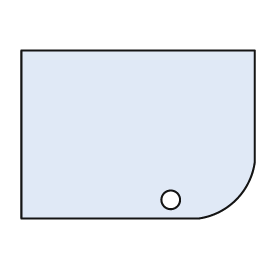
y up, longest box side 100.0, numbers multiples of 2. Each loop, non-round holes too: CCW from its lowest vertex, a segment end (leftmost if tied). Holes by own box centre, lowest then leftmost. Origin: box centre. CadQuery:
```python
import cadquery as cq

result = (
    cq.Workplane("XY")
    .moveTo(-50.0, -36.0)
    .lineTo(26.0, -36.0)
    .threePointArc((42.0, -28.0), (50.0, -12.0))
    .lineTo(50.0, 36.0)
    .lineTo(-50.0, 36.0)
    .close()
    .moveTo(14.0, -28.0)
    .circle(4.0)
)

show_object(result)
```